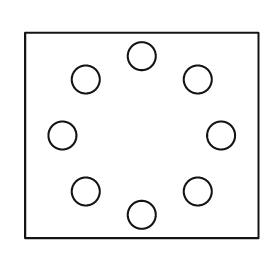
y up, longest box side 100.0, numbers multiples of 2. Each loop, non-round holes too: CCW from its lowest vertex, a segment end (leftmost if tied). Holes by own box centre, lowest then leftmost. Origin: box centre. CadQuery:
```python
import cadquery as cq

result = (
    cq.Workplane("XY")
    .moveTo(-50.0, -44.0)
    .lineTo(50.0, -44.0)
    .lineTo(50.0, 44.0)
    .lineTo(-50.0, 44.0)
    .close()
    .moveTo(0.0, -34.0)
    .circle(6.0)
    .moveTo(-24.0, -24.0)
    .circle(6.0)
    .moveTo(24.0, -24.0)
    .circle(6.0)
    .moveTo(-34.0, 0.0)
    .circle(6.0)
    .moveTo(34.0, 0.0)
    .circle(6.0)
    .moveTo(-24.0, 24.0)
    .circle(6.0)
    .moveTo(24.0, 24.0)
    .circle(6.0)
    .moveTo(0.0, 34.0)
    .circle(6.0)
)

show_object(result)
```